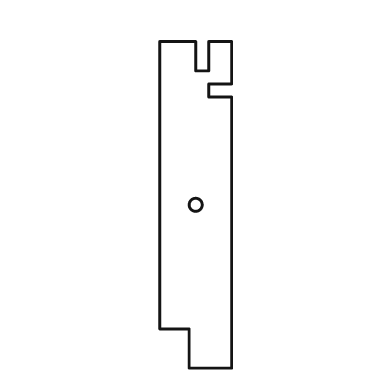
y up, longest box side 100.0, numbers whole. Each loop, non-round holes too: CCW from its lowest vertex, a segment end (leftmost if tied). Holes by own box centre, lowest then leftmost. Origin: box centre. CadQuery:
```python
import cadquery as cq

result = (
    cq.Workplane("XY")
    .moveTo(-2.0, -50.0)
    .lineTo(11.0, -50.0)
    .lineTo(11.0, 33.0)
    .lineTo(4.0, 33.0)
    .lineTo(4.0, 37.0)
    .lineTo(11.0, 37.0)
    .lineTo(11.0, 50.0)
    .lineTo(4.0, 50.0)
    .lineTo(4.0, 41.0)
    .lineTo(0.0, 41.0)
    .lineTo(0.0, 50.0)
    .lineTo(-11.0, 50.0)
    .lineTo(-11.0, -38.0)
    .lineTo(-2.0, -38.0)
    .close()
    .moveTo(0.0, 0.0)
    .circle(2.0)
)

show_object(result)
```